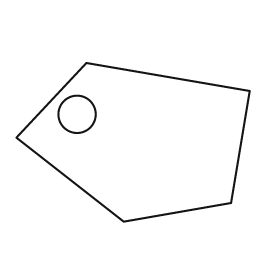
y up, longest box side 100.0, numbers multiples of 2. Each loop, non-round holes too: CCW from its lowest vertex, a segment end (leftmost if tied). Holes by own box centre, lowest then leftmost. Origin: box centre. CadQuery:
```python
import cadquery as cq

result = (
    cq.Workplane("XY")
    .moveTo(-4.0, -34.0)
    .lineTo(42.0, -26.0)
    .lineTo(50.0, 22.0)
    .lineTo(-20.0, 34.0)
    .lineTo(-50.0, 2.0)
    .close()
    .moveTo(-24.0, 12.0)
    .circle(8.0)
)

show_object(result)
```